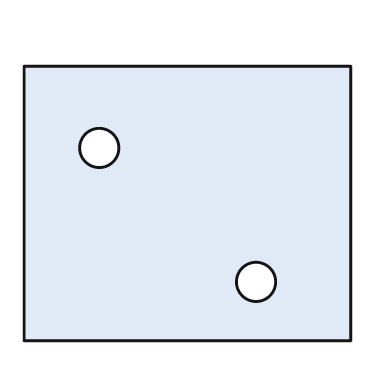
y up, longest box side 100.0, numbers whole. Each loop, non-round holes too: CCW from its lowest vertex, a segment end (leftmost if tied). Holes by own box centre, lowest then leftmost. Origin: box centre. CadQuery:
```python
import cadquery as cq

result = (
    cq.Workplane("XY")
    .moveTo(-50.0, -42.0)
    .lineTo(50.0, -42.0)
    .lineTo(50.0, 42.0)
    .lineTo(-50.0, 42.0)
    .close()
    .moveTo(21.0, -24.0)
    .circle(6.0)
    .moveTo(-27.0, 17.0)
    .circle(6.0)
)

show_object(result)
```